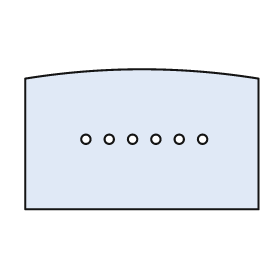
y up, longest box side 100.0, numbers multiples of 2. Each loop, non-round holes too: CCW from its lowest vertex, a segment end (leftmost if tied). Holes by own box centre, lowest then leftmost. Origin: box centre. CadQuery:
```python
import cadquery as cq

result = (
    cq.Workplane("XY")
    .moveTo(-50.0, -30.0)
    .lineTo(50.0, -30.0)
    .lineTo(50.0, 26.0)
    .threePointArc((0.0, 30.0), (-50.0, 26.0))
    .close()
    .moveTo(-24.0, 0.0)
    .circle(2.0)
    .moveTo(-14.0, 0.0)
    .circle(2.0)
    .moveTo(-4.0, 0.0)
    .circle(2.0)
    .moveTo(6.0, 0.0)
    .circle(2.0)
    .moveTo(16.0, 0.0)
    .circle(2.0)
    .moveTo(26.0, 0.0)
    .circle(2.0)
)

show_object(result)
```